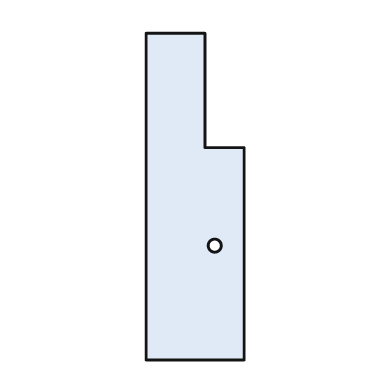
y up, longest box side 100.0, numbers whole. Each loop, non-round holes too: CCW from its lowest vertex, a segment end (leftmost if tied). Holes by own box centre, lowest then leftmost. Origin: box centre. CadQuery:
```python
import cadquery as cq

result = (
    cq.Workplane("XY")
    .moveTo(-15.0, -50.0)
    .lineTo(15.0, -50.0)
    .lineTo(15.0, 15.0)
    .lineTo(3.0, 15.0)
    .lineTo(3.0, 50.0)
    .lineTo(-15.0, 50.0)
    .close()
    .moveTo(6.0, -15.0)
    .circle(2.0)
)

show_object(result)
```